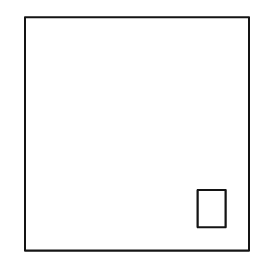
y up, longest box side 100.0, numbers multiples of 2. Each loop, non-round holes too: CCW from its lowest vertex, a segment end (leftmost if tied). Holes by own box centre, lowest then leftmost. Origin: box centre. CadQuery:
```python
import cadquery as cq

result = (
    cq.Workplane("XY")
    .moveTo(-48.0, -50.0)
    .lineTo(48.0, -50.0)
    .lineTo(48.0, 50.0)
    .lineTo(-48.0, 50.0)
    .close()
    .moveTo(26.0, -40.0)
    .lineTo(38.0, -40.0)
    .lineTo(38.0, -24.0)
    .lineTo(26.0, -24.0)
    .close()
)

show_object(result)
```